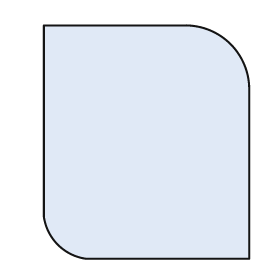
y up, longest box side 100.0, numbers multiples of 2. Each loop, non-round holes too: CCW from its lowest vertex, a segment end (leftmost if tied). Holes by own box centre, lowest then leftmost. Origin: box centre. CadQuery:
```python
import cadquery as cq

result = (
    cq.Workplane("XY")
    .moveTo(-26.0, -50.0)
    .lineTo(44.0, -50.0)
    .lineTo(44.0, 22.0)
    .threePointArc((36.0, 42.0), (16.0, 50.0))
    .lineTo(-44.0, 50.0)
    .lineTo(-44.0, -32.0)
    .threePointArc((-38.0, -44.0), (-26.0, -50.0))
    .close()
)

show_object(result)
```